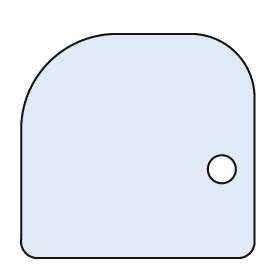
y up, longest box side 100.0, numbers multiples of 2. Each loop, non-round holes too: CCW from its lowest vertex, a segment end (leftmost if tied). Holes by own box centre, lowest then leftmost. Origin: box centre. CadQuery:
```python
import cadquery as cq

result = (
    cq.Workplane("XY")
    .moveTo(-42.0, -48.0)
    .lineTo(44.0, -48.0)
    .threePointArc((48.0, -46.0), (50.0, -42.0))
    .lineTo(50.0, 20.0)
    .threePointArc((42.0, 40.0), (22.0, 48.0))
    .lineTo(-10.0, 48.0)
    .threePointArc((-38.0, 36.0), (-50.0, 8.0))
    .lineTo(-50.0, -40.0)
    .threePointArc((-48.0, -46.0), (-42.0, -48.0))
    .close()
    .moveTo(36.0, -10.0)
    .circle(6.0)
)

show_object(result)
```